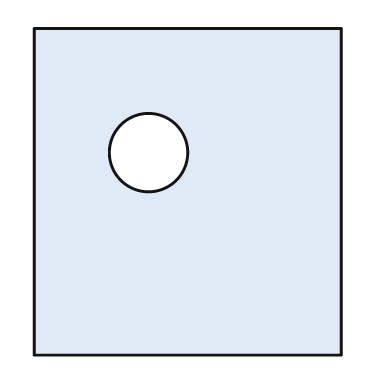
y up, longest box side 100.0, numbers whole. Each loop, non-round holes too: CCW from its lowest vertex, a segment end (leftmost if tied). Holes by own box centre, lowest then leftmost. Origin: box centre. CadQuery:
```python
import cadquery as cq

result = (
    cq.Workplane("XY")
    .moveTo(-47.0, -50.0)
    .lineTo(47.0, -50.0)
    .lineTo(47.0, 50.0)
    .lineTo(-47.0, 50.0)
    .close()
    .moveTo(-12.0, 12.0)
    .circle(12.0)
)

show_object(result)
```